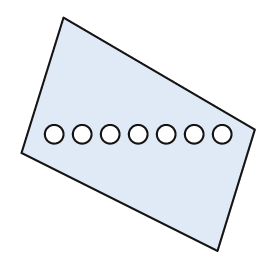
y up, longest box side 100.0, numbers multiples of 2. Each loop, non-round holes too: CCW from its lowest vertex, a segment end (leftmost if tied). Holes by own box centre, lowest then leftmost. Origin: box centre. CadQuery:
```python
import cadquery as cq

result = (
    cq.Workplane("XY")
    .moveTo(34.0, -50.0)
    .lineTo(50.0, 2.0)
    .lineTo(-32.0, 50.0)
    .lineTo(-50.0, -8.0)
    .close()
    .moveTo(-36.0, 0.0)
    .circle(4.0)
    .moveTo(-24.0, 0.0)
    .circle(4.0)
    .moveTo(-12.0, 0.0)
    .circle(4.0)
    .moveTo(0.0, 0.0)
    .circle(4.0)
    .moveTo(12.0, 0.0)
    .circle(4.0)
    .moveTo(24.0, 0.0)
    .circle(4.0)
    .moveTo(36.0, 0.0)
    .circle(4.0)
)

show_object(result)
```